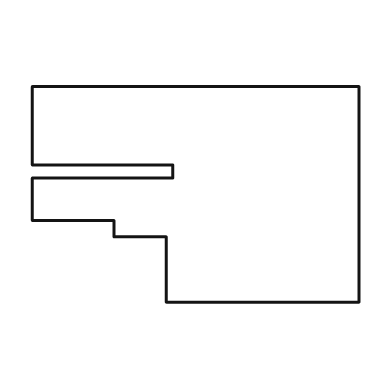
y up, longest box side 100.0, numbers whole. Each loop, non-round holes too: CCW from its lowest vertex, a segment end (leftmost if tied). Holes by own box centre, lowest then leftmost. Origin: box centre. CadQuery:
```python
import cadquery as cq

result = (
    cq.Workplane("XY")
    .moveTo(-9.0, -33.0)
    .lineTo(50.0, -33.0)
    .lineTo(50.0, 33.0)
    .lineTo(-50.0, 33.0)
    .lineTo(-50.0, 9.0)
    .lineTo(-7.0, 9.0)
    .lineTo(-7.0, 5.0)
    .lineTo(-50.0, 5.0)
    .lineTo(-50.0, -8.0)
    .lineTo(-25.0, -8.0)
    .lineTo(-25.0, -13.0)
    .lineTo(-9.0, -13.0)
    .close()
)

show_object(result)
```